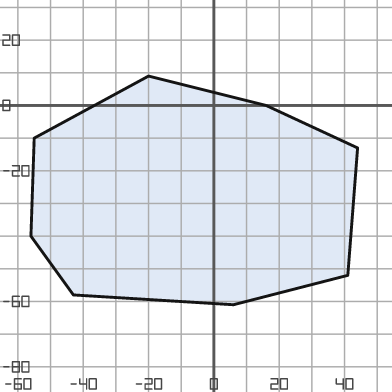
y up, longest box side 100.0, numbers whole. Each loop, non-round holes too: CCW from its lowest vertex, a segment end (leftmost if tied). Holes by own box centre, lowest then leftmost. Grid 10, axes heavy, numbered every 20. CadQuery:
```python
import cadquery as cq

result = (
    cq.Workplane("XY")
    .moveTo(6.0, -61.0)
    .lineTo(41.0, -52.0)
    .lineTo(44.0, -13.0)
    .lineTo(16.0, 0.0)
    .lineTo(-20.0, 9.0)
    .lineTo(-55.0, -10.0)
    .lineTo(-56.0, -40.0)
    .lineTo(-43.0, -58.0)
    .close()
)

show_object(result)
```